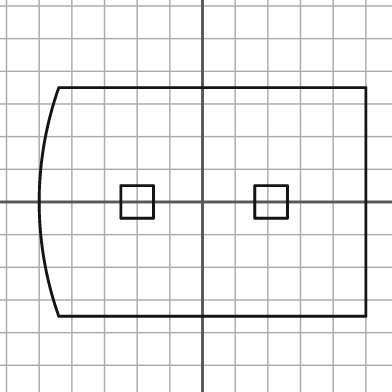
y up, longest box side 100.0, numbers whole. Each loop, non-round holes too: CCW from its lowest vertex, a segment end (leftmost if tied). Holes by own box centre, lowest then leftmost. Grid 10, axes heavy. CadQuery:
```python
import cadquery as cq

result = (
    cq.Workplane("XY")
    .moveTo(-44.0, -35.0)
    .lineTo(50.0, -35.0)
    .lineTo(50.0, 35.0)
    .lineTo(-44.0, 35.0)
    .threePointArc((-50.0, 0.0), (-44.0, -35.0))
    .close()
    .moveTo(-25.0, -5.0)
    .lineTo(-15.0, -5.0)
    .lineTo(-15.0, 5.0)
    .lineTo(-25.0, 5.0)
    .close()
    .moveTo(16.0, -5.0)
    .lineTo(26.0, -5.0)
    .lineTo(26.0, 5.0)
    .lineTo(16.0, 5.0)
    .close()
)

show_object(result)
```